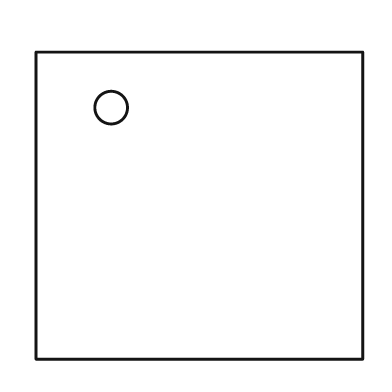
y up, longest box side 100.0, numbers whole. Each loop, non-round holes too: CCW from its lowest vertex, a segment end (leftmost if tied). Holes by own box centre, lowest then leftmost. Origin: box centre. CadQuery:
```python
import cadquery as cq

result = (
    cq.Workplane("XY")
    .moveTo(-50.0, -47.0)
    .lineTo(50.0, -47.0)
    .lineTo(50.0, 47.0)
    .lineTo(-50.0, 47.0)
    .close()
    .moveTo(-27.0, 30.0)
    .circle(5.0)
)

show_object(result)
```